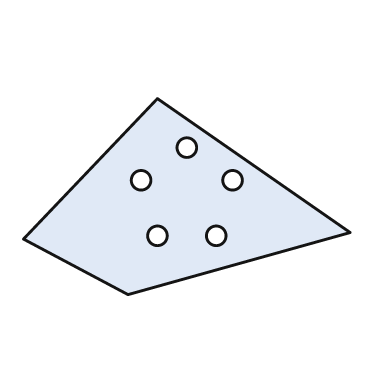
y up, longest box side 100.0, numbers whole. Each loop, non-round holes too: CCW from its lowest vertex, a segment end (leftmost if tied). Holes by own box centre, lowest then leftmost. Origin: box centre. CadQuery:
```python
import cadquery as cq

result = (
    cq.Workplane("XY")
    .moveTo(-18.0, -30.0)
    .lineTo(50.0, -11.0)
    .lineTo(-9.0, 30.0)
    .lineTo(-50.0, -13.0)
    .close()
    .moveTo(-9.0, -12.0)
    .circle(3.0)
    .moveTo(9.0, -12.0)
    .circle(3.0)
    .moveTo(-14.0, 5.0)
    .circle(3.0)
    .moveTo(14.0, 5.0)
    .circle(3.0)
    .moveTo(0.0, 15.0)
    .circle(3.0)
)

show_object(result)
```